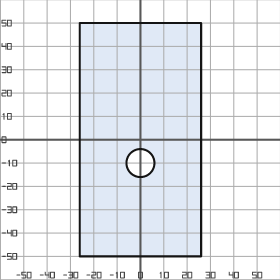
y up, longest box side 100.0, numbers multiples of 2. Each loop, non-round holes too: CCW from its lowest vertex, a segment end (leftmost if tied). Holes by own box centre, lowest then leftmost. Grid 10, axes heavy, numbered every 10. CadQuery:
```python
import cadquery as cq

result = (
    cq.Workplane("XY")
    .moveTo(-26.0, -50.0)
    .lineTo(26.0, -50.0)
    .lineTo(26.0, 50.0)
    .lineTo(-26.0, 50.0)
    .close()
    .moveTo(0.0, -10.0)
    .circle(6.0)
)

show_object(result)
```